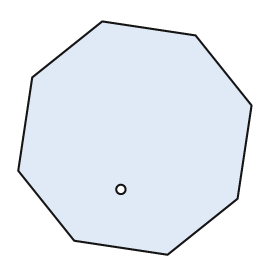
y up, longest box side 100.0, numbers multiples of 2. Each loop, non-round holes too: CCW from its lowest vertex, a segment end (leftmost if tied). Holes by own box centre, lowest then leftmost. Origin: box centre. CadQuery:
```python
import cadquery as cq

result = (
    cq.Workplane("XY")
    .moveTo(14.0, -50.0)
    .lineTo(44.0, -26.0)
    .lineTo(50.0, 14.0)
    .lineTo(26.0, 44.0)
    .lineTo(-14.0, 50.0)
    .lineTo(-44.0, 26.0)
    .lineTo(-50.0, -14.0)
    .lineTo(-26.0, -44.0)
    .close()
    .moveTo(-6.0, -22.0)
    .circle(2.0)
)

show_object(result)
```